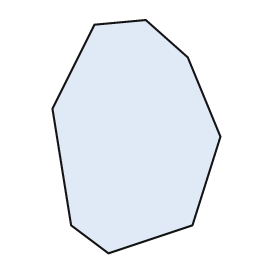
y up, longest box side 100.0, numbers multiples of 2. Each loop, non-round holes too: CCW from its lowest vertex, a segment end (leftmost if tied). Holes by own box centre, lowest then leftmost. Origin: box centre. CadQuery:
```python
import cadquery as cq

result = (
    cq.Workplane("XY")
    .moveTo(-12.0, -50.0)
    .lineTo(24.0, -38.0)
    .lineTo(36.0, 0.0)
    .lineTo(22.0, 34.0)
    .lineTo(4.0, 50.0)
    .lineTo(-18.0, 48.0)
    .lineTo(-36.0, 12.0)
    .lineTo(-28.0, -38.0)
    .close()
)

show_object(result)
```